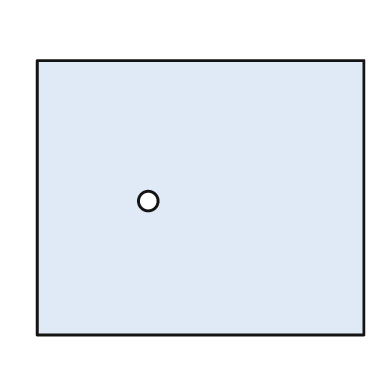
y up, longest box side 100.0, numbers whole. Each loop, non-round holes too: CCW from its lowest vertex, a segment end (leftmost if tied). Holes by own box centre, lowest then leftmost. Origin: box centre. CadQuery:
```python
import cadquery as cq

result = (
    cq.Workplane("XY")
    .moveTo(-50.0, -42.0)
    .lineTo(50.0, -42.0)
    .lineTo(50.0, 42.0)
    .lineTo(-50.0, 42.0)
    .close()
    .moveTo(-16.0, -1.0)
    .circle(3.0)
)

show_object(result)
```